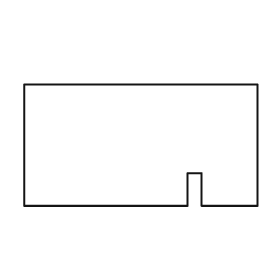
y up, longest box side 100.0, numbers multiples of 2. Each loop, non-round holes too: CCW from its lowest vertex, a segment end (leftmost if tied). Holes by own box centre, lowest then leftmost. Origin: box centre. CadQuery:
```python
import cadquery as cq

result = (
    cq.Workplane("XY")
    .moveTo(-50.0, -26.0)
    .lineTo(20.0, -26.0)
    .lineTo(20.0, -12.0)
    .lineTo(26.0, -12.0)
    .lineTo(26.0, -26.0)
    .lineTo(50.0, -26.0)
    .lineTo(50.0, 26.0)
    .lineTo(-50.0, 26.0)
    .close()
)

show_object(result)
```